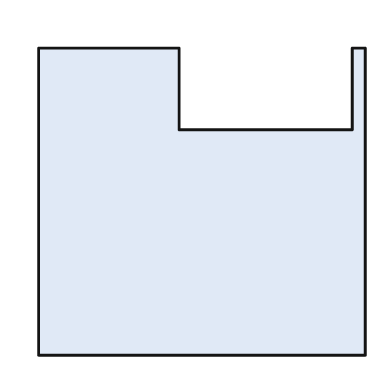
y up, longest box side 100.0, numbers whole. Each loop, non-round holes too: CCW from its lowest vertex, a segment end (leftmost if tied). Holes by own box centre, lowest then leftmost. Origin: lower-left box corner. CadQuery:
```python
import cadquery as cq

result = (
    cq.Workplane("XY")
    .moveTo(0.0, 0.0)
    .lineTo(100.0, 0.0)
    .lineTo(100.0, 94.0)
    .lineTo(96.0, 94.0)
    .lineTo(96.0, 69.0)
    .lineTo(43.0, 69.0)
    .lineTo(43.0, 94.0)
    .lineTo(0.0, 94.0)
    .close()
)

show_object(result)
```